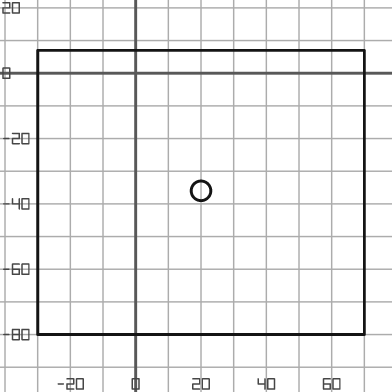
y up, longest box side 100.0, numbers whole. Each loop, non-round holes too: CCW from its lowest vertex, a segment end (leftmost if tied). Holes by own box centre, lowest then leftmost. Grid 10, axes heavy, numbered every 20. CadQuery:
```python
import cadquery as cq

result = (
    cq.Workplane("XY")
    .moveTo(-30.0, -80.0)
    .lineTo(70.0, -80.0)
    .lineTo(70.0, 7.0)
    .lineTo(-30.0, 7.0)
    .close()
    .moveTo(20.0, -36.0)
    .circle(3.0)
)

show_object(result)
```